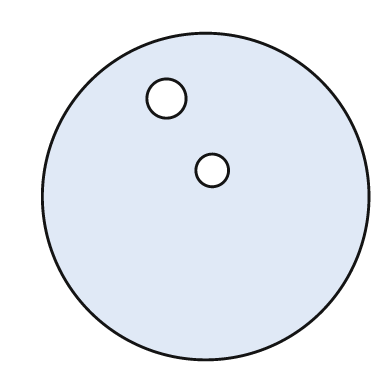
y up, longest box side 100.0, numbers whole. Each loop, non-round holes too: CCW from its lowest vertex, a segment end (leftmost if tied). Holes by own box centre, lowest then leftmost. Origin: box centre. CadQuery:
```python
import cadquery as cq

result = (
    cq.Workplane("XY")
    .moveTo(0.0, 0.0)
    .circle(50.0)
    .moveTo(2.0, 8.0)
    .circle(5.0)
    .moveTo(-12.0, 30.0)
    .circle(6.0)
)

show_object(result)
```